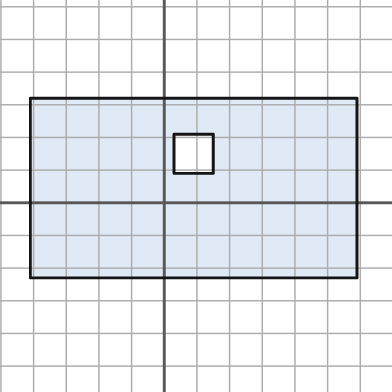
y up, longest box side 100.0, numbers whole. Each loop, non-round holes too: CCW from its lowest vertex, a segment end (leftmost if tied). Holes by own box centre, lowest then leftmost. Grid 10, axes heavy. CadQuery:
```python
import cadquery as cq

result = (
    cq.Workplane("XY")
    .moveTo(-41.0, -23.0)
    .lineTo(59.0, -23.0)
    .lineTo(59.0, 32.0)
    .lineTo(-41.0, 32.0)
    .close()
    .moveTo(3.0, 9.0)
    .lineTo(15.0, 9.0)
    .lineTo(15.0, 21.0)
    .lineTo(3.0, 21.0)
    .close()
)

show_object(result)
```